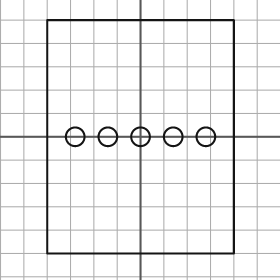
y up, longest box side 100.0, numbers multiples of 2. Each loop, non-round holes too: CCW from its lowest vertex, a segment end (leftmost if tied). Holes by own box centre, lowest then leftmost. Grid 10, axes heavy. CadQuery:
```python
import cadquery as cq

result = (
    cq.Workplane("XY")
    .moveTo(-40.0, -50.0)
    .lineTo(40.0, -50.0)
    .lineTo(40.0, 50.0)
    .lineTo(-40.0, 50.0)
    .close()
    .moveTo(-28.0, 0.0)
    .circle(4.0)
    .moveTo(-14.0, 0.0)
    .circle(4.0)
    .moveTo(0.0, 0.0)
    .circle(4.0)
    .moveTo(14.0, 0.0)
    .circle(4.0)
    .moveTo(28.0, 0.0)
    .circle(4.0)
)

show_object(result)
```